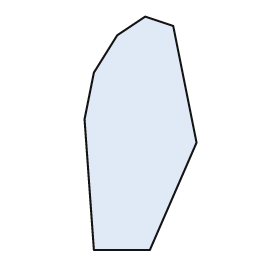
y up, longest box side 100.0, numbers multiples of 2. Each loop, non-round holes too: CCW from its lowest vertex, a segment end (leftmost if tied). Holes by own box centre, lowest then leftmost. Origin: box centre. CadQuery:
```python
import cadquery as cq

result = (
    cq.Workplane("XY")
    .moveTo(-20.0, -50.0)
    .lineTo(4.0, -50.0)
    .lineTo(24.0, -4.0)
    .lineTo(14.0, 46.0)
    .lineTo(2.0, 50.0)
    .lineTo(-10.0, 42.0)
    .lineTo(-20.0, 26.0)
    .lineTo(-24.0, 6.0)
    .close()
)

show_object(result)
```